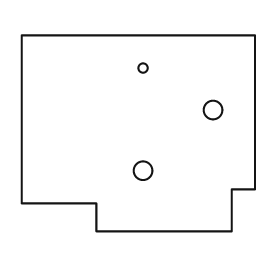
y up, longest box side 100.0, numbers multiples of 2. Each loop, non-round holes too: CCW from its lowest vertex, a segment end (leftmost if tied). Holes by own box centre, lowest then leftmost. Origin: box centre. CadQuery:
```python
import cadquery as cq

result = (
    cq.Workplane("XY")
    .moveTo(-18.0, -42.0)
    .lineTo(40.0, -42.0)
    .lineTo(40.0, -24.0)
    .lineTo(50.0, -24.0)
    .lineTo(50.0, 42.0)
    .lineTo(-50.0, 42.0)
    .lineTo(-50.0, -30.0)
    .lineTo(-18.0, -30.0)
    .close()
    .moveTo(2.0, -16.0)
    .circle(4.0)
    .moveTo(32.0, 10.0)
    .circle(4.0)
    .moveTo(2.0, 28.0)
    .circle(2.0)
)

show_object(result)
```